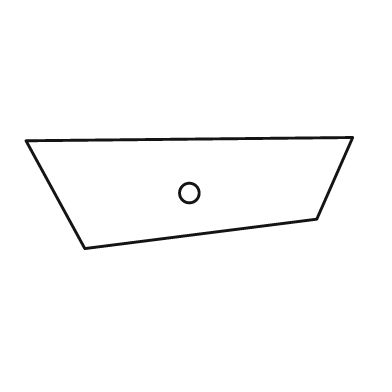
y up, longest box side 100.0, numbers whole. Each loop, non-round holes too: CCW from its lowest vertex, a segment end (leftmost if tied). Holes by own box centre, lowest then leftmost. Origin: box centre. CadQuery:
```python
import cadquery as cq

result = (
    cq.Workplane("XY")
    .moveTo(-32.0, -17.0)
    .lineTo(39.0, -8.0)
    .lineTo(50.0, 17.0)
    .lineTo(-50.0, 16.0)
    .close()
    .moveTo(0.0, 0.0)
    .circle(3.0)
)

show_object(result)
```